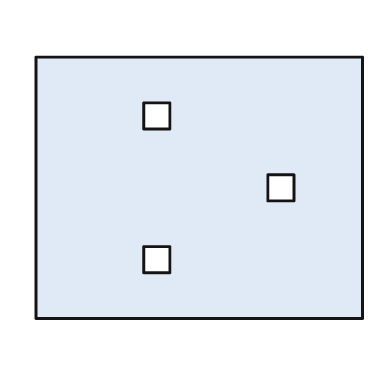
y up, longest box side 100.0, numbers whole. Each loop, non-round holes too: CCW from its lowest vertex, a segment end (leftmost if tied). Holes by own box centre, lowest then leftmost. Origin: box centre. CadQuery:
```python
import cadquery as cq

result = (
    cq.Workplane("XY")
    .moveTo(-50.0, -40.0)
    .lineTo(50.0, -40.0)
    .lineTo(50.0, 40.0)
    .lineTo(-50.0, 40.0)
    .close()
    .moveTo(-17.0, -26.0)
    .lineTo(-9.0, -26.0)
    .lineTo(-9.0, -18.0)
    .lineTo(-17.0, -18.0)
    .close()
    .moveTo(21.0, -4.0)
    .lineTo(29.0, -4.0)
    .lineTo(29.0, 4.0)
    .lineTo(21.0, 4.0)
    .close()
    .moveTo(-17.0, 18.0)
    .lineTo(-9.0, 18.0)
    .lineTo(-9.0, 26.0)
    .lineTo(-17.0, 26.0)
    .close()
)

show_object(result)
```